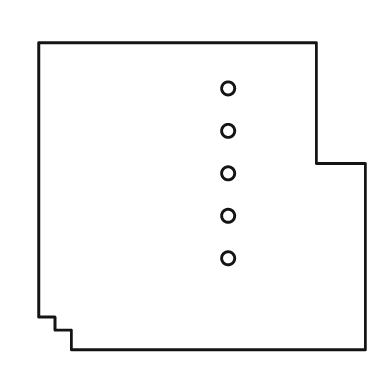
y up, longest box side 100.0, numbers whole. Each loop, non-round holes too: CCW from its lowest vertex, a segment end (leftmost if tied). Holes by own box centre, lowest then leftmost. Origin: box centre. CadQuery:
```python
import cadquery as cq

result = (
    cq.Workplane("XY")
    .moveTo(-40.0, -47.0)
    .lineTo(50.0, -47.0)
    .lineTo(50.0, 10.0)
    .lineTo(35.0, 10.0)
    .lineTo(35.0, 47.0)
    .lineTo(-50.0, 47.0)
    .lineTo(-50.0, -37.0)
    .lineTo(-45.0, -37.0)
    .lineTo(-45.0, -41.0)
    .lineTo(-40.0, -41.0)
    .close()
    .moveTo(8.0, -19.0)
    .circle(2.0)
    .moveTo(8.0, -6.0)
    .circle(2.0)
    .moveTo(8.0, 7.0)
    .circle(2.0)
    .moveTo(8.0, 20.0)
    .circle(2.0)
    .moveTo(8.0, 33.0)
    .circle(2.0)
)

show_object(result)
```